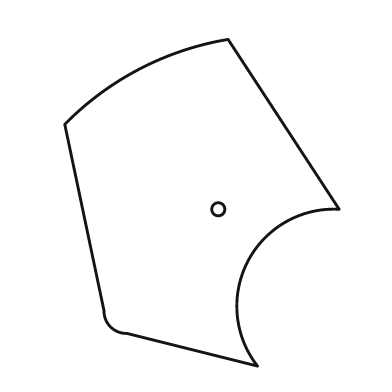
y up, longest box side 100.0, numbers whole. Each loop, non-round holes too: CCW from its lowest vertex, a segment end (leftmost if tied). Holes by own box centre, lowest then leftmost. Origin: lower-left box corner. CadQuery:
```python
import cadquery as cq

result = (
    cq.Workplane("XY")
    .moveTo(59.0, 0.0)
    .threePointArc((56.0, 32.0), (84.0, 48.0))
    .lineTo(50.0, 100.0)
    .threePointArc((23.0, 91.0), (0.0, 74.0))
    .lineTo(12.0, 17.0)
    .threePointArc((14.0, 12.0), (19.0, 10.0))
    .close()
    .moveTo(47.0, 48.0)
    .circle(2.0)
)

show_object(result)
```